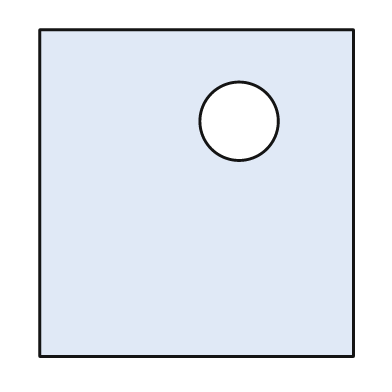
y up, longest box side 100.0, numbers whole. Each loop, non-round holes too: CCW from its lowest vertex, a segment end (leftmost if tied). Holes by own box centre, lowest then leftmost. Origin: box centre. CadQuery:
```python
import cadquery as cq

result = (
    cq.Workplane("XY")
    .moveTo(-48.0, -50.0)
    .lineTo(48.0, -50.0)
    .lineTo(48.0, 50.0)
    .lineTo(-48.0, 50.0)
    .close()
    .moveTo(13.0, 22.0)
    .circle(12.0)
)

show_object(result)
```